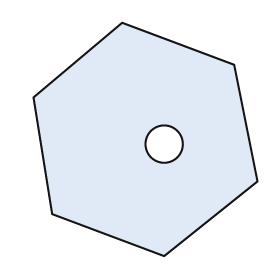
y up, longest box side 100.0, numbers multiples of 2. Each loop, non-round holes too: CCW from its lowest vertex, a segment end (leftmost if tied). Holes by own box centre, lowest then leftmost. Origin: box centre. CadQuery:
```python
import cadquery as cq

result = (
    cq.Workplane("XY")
    .moveTo(8.0, -50.0)
    .lineTo(48.0, -18.0)
    .lineTo(38.0, 32.0)
    .lineTo(-10.0, 50.0)
    .lineTo(-48.0, 18.0)
    .lineTo(-40.0, -32.0)
    .close()
    .moveTo(8.0, -2.0)
    .circle(8.0)
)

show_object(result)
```